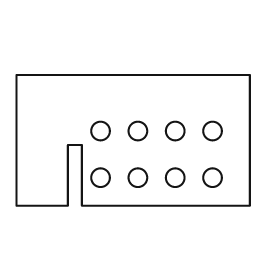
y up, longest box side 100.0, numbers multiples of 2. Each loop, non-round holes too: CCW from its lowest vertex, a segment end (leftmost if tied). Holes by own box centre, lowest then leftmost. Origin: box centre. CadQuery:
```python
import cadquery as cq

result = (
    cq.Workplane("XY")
    .moveTo(-50.0, -28.0)
    .lineTo(-28.0, -28.0)
    .lineTo(-28.0, -2.0)
    .lineTo(-22.0, -2.0)
    .lineTo(-22.0, -28.0)
    .lineTo(50.0, -28.0)
    .lineTo(50.0, 28.0)
    .lineTo(-50.0, 28.0)
    .close()
    .moveTo(-14.0, -16.0)
    .circle(4.0)
    .moveTo(2.0, -16.0)
    .circle(4.0)
    .moveTo(18.0, -16.0)
    .circle(4.0)
    .moveTo(34.0, -16.0)
    .circle(4.0)
    .moveTo(-14.0, 4.0)
    .circle(4.0)
    .moveTo(2.0, 4.0)
    .circle(4.0)
    .moveTo(18.0, 4.0)
    .circle(4.0)
    .moveTo(34.0, 4.0)
    .circle(4.0)
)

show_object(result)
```